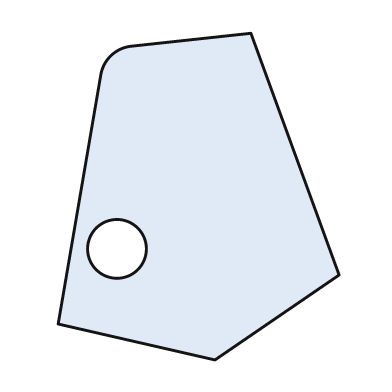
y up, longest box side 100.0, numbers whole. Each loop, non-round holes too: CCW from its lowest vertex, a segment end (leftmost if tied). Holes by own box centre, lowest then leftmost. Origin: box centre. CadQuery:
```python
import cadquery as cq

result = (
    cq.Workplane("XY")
    .moveTo(5.0, -50.0)
    .lineTo(43.0, -24.0)
    .lineTo(16.0, 50.0)
    .lineTo(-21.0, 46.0)
    .threePointArc((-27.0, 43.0), (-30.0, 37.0))
    .lineTo(-43.0, -39.0)
    .close()
    .moveTo(-25.0, -16.0)
    .circle(9.0)
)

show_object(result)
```